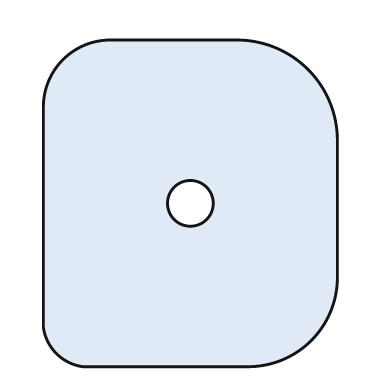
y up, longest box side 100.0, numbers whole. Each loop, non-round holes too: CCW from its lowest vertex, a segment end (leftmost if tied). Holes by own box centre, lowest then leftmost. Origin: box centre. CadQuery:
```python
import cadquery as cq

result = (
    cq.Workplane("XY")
    .moveTo(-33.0, -50.0)
    .lineTo(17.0, -50.0)
    .threePointArc((37.0, -42.0), (45.0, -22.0))
    .lineTo(45.0, 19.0)
    .threePointArc((36.0, 41.0), (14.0, 50.0))
    .lineTo(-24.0, 50.0)
    .threePointArc((-39.0, 44.0), (-45.0, 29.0))
    .lineTo(-45.0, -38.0)
    .threePointArc((-41.0, -46.0), (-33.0, -50.0))
    .close()
    .moveTo(0.0, 0.0)
    .circle(7.0)
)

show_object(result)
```